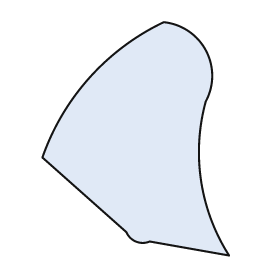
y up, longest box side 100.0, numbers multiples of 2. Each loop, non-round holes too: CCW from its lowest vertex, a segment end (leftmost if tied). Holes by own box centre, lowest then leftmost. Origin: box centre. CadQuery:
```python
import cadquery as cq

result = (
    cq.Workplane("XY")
    .moveTo(40.0, -50.0)
    .threePointArc((28.0, -18.0), (30.0, 16.0))
    .threePointArc((30.0, 38.0), (12.0, 50.0))
    .threePointArc((-20.0, 26.0), (-40.0, -8.0))
    .lineTo(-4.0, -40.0)
    .threePointArc((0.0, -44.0), (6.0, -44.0))
    .close()
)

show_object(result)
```